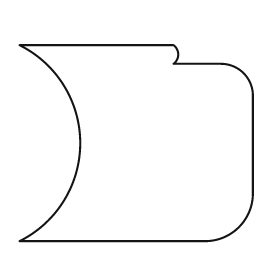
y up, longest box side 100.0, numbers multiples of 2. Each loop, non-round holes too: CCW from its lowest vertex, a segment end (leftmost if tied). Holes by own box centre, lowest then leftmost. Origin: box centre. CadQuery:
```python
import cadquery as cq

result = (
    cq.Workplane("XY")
    .moveTo(-50.0, -42.0)
    .lineTo(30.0, -42.0)
    .threePointArc((44.0, -36.0), (50.0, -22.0))
    .lineTo(50.0, 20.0)
    .threePointArc((46.0, 30.0), (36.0, 34.0))
    .lineTo(16.0, 34.0)
    .threePointArc((18.0, 38.0), (16.0, 42.0))
    .lineTo(-50.0, 42.0)
    .threePointArc((-24.0, 0.0), (-50.0, -42.0))
    .close()
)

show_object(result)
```